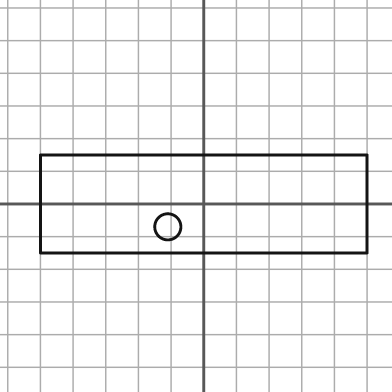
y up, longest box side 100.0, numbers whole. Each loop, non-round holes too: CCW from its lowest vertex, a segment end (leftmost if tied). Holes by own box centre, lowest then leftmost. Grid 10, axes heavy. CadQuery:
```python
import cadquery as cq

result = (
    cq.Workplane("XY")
    .moveTo(-50.0, -15.0)
    .lineTo(50.0, -15.0)
    .lineTo(50.0, 15.0)
    .lineTo(-50.0, 15.0)
    .close()
    .moveTo(-11.0, -7.0)
    .circle(4.0)
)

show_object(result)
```